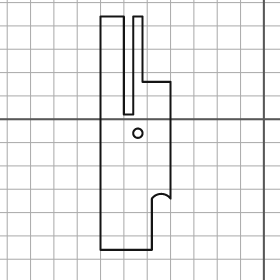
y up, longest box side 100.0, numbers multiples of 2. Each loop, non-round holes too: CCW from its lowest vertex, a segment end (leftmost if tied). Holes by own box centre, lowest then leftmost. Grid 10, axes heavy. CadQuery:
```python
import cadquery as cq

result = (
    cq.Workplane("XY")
    .moveTo(-70.0, -56.0)
    .lineTo(-48.0, -56.0)
    .lineTo(-48.0, -34.0)
    .threePointArc((-44.0, -32.0), (-40.0, -34.0))
    .lineTo(-40.0, 16.0)
    .lineTo(-52.0, 16.0)
    .lineTo(-52.0, 44.0)
    .lineTo(-56.0, 44.0)
    .lineTo(-56.0, 2.0)
    .lineTo(-60.0, 2.0)
    .lineTo(-60.0, 44.0)
    .lineTo(-70.0, 44.0)
    .close()
    .moveTo(-54.0, -6.0)
    .circle(2.0)
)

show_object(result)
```